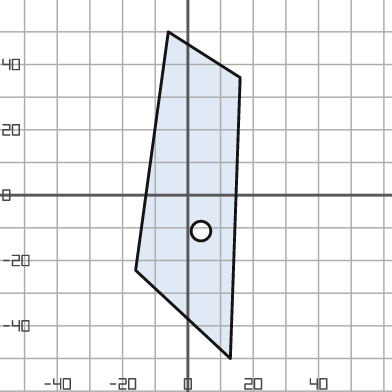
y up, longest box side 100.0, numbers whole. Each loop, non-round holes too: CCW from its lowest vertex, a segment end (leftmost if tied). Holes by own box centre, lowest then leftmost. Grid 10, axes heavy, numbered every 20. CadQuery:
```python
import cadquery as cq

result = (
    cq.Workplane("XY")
    .moveTo(13.0, -50.0)
    .lineTo(16.0, 36.0)
    .lineTo(-6.0, 50.0)
    .lineTo(-16.0, -23.0)
    .close()
    .moveTo(4.0, -11.0)
    .circle(3.0)
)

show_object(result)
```